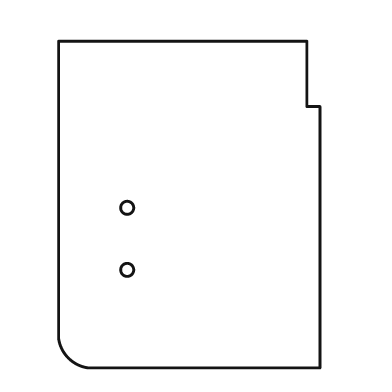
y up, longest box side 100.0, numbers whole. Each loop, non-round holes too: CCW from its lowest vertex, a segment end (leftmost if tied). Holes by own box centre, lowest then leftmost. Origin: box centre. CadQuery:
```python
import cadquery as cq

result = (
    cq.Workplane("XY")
    .moveTo(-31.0, -50.0)
    .lineTo(40.0, -50.0)
    .lineTo(40.0, 30.0)
    .lineTo(36.0, 30.0)
    .lineTo(36.0, 50.0)
    .lineTo(-40.0, 50.0)
    .lineTo(-40.0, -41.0)
    .threePointArc((-37.0, -47.0), (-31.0, -50.0))
    .close()
    .moveTo(-19.0, -20.0)
    .circle(2.0)
    .moveTo(-19.0, -1.0)
    .circle(2.0)
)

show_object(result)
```